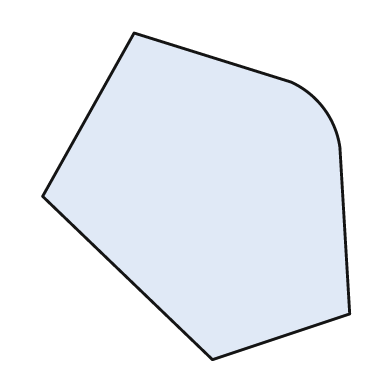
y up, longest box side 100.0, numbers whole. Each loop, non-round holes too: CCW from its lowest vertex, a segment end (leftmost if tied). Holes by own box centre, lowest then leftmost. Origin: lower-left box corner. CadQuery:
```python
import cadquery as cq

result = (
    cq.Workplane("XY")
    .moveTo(52.0, 0.0)
    .lineTo(94.0, 14.0)
    .lineTo(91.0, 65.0)
    .threePointArc((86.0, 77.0), (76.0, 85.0))
    .lineTo(28.0, 100.0)
    .lineTo(0.0, 50.0)
    .close()
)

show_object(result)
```